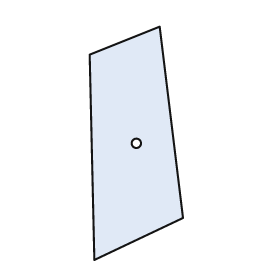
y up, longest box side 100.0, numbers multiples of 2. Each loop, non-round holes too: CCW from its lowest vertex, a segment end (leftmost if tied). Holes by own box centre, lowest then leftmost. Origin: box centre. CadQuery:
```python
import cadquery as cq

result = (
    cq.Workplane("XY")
    .moveTo(-18.0, -50.0)
    .lineTo(20.0, -32.0)
    .lineTo(10.0, 50.0)
    .lineTo(-20.0, 38.0)
    .close()
    .moveTo(0.0, 0.0)
    .circle(2.0)
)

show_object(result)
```